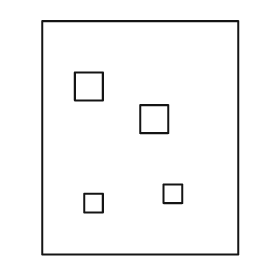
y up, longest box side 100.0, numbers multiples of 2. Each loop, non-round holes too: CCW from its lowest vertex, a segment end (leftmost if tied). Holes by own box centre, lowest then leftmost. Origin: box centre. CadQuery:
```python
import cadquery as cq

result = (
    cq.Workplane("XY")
    .moveTo(-42.0, -50.0)
    .lineTo(42.0, -50.0)
    .lineTo(42.0, 50.0)
    .lineTo(-42.0, 50.0)
    .close()
    .moveTo(-24.0, -32.0)
    .lineTo(-16.0, -32.0)
    .lineTo(-16.0, -24.0)
    .lineTo(-24.0, -24.0)
    .close()
    .moveTo(10.0, -28.0)
    .lineTo(18.0, -28.0)
    .lineTo(18.0, -20.0)
    .lineTo(10.0, -20.0)
    .close()
    .moveTo(0.0, 2.0)
    .lineTo(12.0, 2.0)
    .lineTo(12.0, 14.0)
    .lineTo(0.0, 14.0)
    .close()
    .moveTo(-28.0, 16.0)
    .lineTo(-16.0, 16.0)
    .lineTo(-16.0, 28.0)
    .lineTo(-28.0, 28.0)
    .close()
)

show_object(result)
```